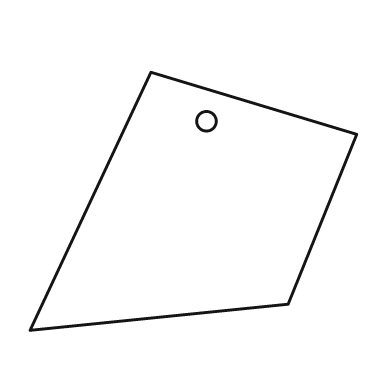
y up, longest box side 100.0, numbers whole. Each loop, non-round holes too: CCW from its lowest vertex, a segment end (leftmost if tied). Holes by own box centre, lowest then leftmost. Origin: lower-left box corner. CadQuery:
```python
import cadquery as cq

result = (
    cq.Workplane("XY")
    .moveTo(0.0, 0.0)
    .lineTo(79.0, 8.0)
    .lineTo(100.0, 60.0)
    .lineTo(37.0, 79.0)
    .close()
    .moveTo(54.0, 64.0)
    .circle(3.0)
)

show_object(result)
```